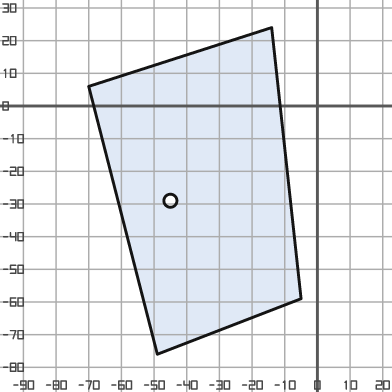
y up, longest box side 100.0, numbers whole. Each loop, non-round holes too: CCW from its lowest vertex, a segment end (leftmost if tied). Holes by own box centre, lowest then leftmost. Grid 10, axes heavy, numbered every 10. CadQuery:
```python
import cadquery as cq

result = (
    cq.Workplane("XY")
    .moveTo(-49.0, -76.0)
    .lineTo(-5.0, -59.0)
    .lineTo(-14.0, 24.0)
    .lineTo(-70.0, 6.0)
    .close()
    .moveTo(-45.0, -29.0)
    .circle(2.0)
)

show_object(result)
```